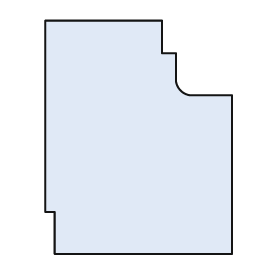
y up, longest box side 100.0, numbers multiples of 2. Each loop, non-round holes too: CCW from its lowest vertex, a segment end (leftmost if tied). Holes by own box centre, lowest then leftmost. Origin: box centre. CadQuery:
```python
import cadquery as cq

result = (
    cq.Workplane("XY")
    .moveTo(-36.0, -50.0)
    .lineTo(40.0, -50.0)
    .lineTo(40.0, 18.0)
    .lineTo(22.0, 18.0)
    .threePointArc((18.0, 20.0), (16.0, 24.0))
    .lineTo(16.0, 36.0)
    .lineTo(10.0, 36.0)
    .lineTo(10.0, 50.0)
    .lineTo(-40.0, 50.0)
    .lineTo(-40.0, -32.0)
    .lineTo(-36.0, -32.0)
    .close()
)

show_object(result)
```